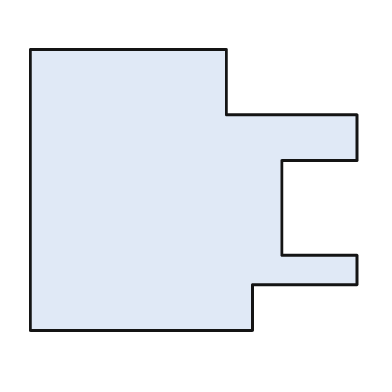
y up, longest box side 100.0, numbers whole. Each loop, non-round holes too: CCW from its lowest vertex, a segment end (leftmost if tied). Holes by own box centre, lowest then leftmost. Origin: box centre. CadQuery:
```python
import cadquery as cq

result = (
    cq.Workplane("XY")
    .moveTo(-50.0, -43.0)
    .lineTo(18.0, -43.0)
    .lineTo(18.0, -29.0)
    .lineTo(50.0, -29.0)
    .lineTo(50.0, -20.0)
    .lineTo(27.0, -20.0)
    .lineTo(27.0, 9.0)
    .lineTo(50.0, 9.0)
    .lineTo(50.0, 23.0)
    .lineTo(10.0, 23.0)
    .lineTo(10.0, 43.0)
    .lineTo(-50.0, 43.0)
    .close()
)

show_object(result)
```